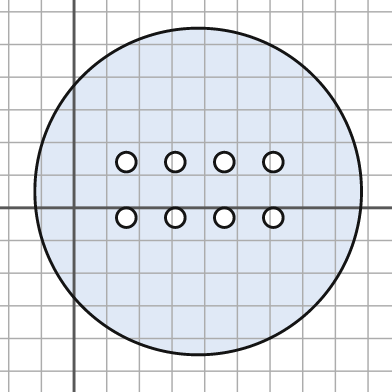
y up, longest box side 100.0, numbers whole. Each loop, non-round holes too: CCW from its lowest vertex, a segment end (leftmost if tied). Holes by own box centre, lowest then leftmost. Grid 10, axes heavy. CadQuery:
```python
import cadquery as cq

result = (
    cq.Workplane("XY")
    .moveTo(38.0, 5.0)
    .circle(50.0)
    .moveTo(16.0, -3.0)
    .circle(3.0)
    .moveTo(31.0, -3.0)
    .circle(3.0)
    .moveTo(46.0, -3.0)
    .circle(3.0)
    .moveTo(61.0, -3.0)
    .circle(3.0)
    .moveTo(16.0, 14.0)
    .circle(3.0)
    .moveTo(31.0, 14.0)
    .circle(3.0)
    .moveTo(46.0, 14.0)
    .circle(3.0)
    .moveTo(61.0, 14.0)
    .circle(3.0)
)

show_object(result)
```